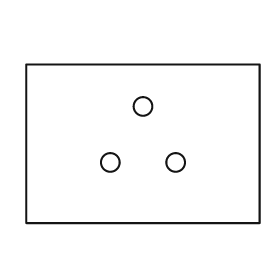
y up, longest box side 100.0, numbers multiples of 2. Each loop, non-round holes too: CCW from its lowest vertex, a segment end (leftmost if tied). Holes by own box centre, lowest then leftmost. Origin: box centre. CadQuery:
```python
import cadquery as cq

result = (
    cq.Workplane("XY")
    .moveTo(-50.0, -34.0)
    .lineTo(50.0, -34.0)
    .lineTo(50.0, 34.0)
    .lineTo(-50.0, 34.0)
    .close()
    .moveTo(-14.0, -8.0)
    .circle(4.0)
    .moveTo(14.0, -8.0)
    .circle(4.0)
    .moveTo(0.0, 16.0)
    .circle(4.0)
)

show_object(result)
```